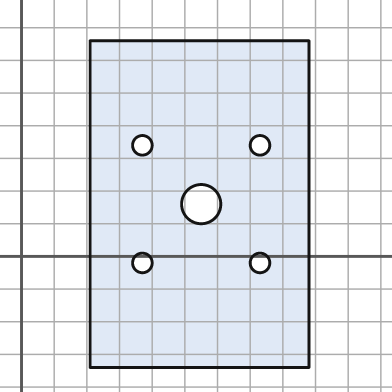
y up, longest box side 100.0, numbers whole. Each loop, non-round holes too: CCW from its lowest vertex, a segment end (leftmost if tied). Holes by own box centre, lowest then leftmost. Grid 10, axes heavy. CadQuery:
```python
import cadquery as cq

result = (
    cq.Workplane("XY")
    .moveTo(21.0, -34.0)
    .lineTo(88.0, -34.0)
    .lineTo(88.0, 66.0)
    .lineTo(21.0, 66.0)
    .close()
    .moveTo(37.0, -2.0)
    .circle(3.0)
    .moveTo(73.0, -2.0)
    .circle(3.0)
    .moveTo(55.0, 16.0)
    .circle(6.0)
    .moveTo(37.0, 34.0)
    .circle(3.0)
    .moveTo(73.0, 34.0)
    .circle(3.0)
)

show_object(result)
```